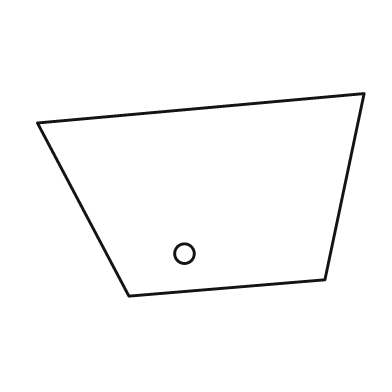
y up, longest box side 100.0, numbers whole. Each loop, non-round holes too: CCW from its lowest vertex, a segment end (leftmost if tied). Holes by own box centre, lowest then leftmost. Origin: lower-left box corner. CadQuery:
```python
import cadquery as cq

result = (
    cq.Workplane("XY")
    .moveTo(28.0, 0.0)
    .lineTo(88.0, 5.0)
    .lineTo(100.0, 62.0)
    .lineTo(0.0, 53.0)
    .close()
    .moveTo(45.0, 13.0)
    .circle(3.0)
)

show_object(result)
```